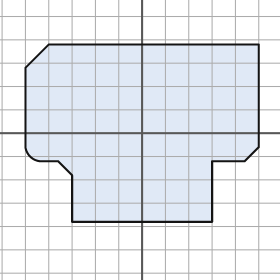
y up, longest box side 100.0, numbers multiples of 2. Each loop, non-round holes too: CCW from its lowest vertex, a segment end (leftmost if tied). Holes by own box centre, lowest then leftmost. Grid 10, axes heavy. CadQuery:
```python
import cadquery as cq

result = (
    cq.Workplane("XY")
    .moveTo(-30.0, -38.0)
    .lineTo(30.0, -38.0)
    .lineTo(30.0, -12.0)
    .lineTo(44.0, -12.0)
    .lineTo(50.0, -6.0)
    .lineTo(50.0, 38.0)
    .lineTo(-40.0, 38.0)
    .lineTo(-50.0, 28.0)
    .lineTo(-50.0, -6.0)
    .threePointArc((-48.0, -10.0), (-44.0, -12.0))
    .lineTo(-36.0, -12.0)
    .lineTo(-30.0, -18.0)
    .close()
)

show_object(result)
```